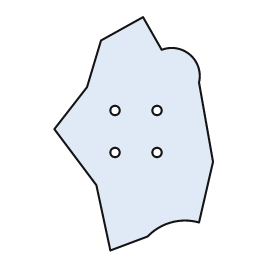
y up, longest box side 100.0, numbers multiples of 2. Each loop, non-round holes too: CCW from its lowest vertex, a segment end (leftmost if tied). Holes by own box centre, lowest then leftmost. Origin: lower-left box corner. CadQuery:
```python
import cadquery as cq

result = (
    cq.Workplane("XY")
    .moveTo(24.0, 0.0)
    .lineTo(40.0, 6.0)
    .threePointArc((50.0, 12.0), (62.0, 12.0))
    .lineTo(68.0, 38.0)
    .lineTo(62.0, 72.0)
    .threePointArc((58.0, 84.0), (46.0, 86.0))
    .lineTo(38.0, 100.0)
    .lineTo(20.0, 90.0)
    .lineTo(14.0, 70.0)
    .lineTo(0.0, 52.0)
    .lineTo(18.0, 28.0)
    .close()
    .moveTo(26.0, 42.0)
    .circle(2.0)
    .moveTo(44.0, 42.0)
    .circle(2.0)
    .moveTo(26.0, 60.0)
    .circle(2.0)
    .moveTo(44.0, 60.0)
    .circle(2.0)
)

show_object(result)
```